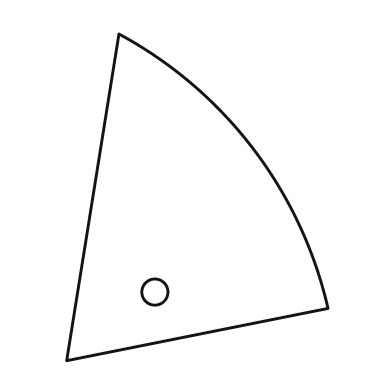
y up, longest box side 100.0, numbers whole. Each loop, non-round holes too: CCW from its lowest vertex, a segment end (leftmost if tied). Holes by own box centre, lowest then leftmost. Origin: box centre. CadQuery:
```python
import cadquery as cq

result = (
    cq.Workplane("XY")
    .moveTo(-40.0, -50.0)
    .lineTo(40.0, -34.0)
    .threePointArc((17.0, 15.0), (-24.0, 50.0))
    .close()
    .moveTo(-13.0, -29.0)
    .circle(4.0)
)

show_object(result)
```